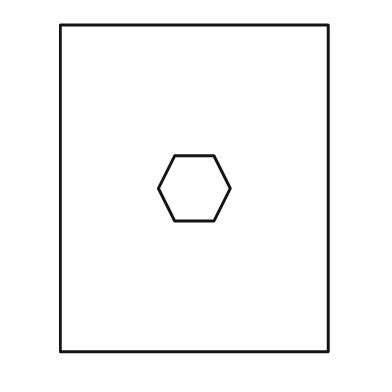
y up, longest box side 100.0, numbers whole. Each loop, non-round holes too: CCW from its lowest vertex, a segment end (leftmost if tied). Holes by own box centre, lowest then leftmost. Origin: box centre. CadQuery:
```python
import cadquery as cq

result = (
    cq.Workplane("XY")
    .moveTo(-41.0, -50.0)
    .lineTo(41.0, -50.0)
    .lineTo(41.0, 50.0)
    .lineTo(-41.0, 50.0)
    .close()
    .moveTo(-6.0, -10.0)
    .lineTo(6.0, -10.0)
    .lineTo(11.0, 0.0)
    .lineTo(6.0, 10.0)
    .lineTo(-6.0, 10.0)
    .lineTo(-11.0, 0.0)
    .close()
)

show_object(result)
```